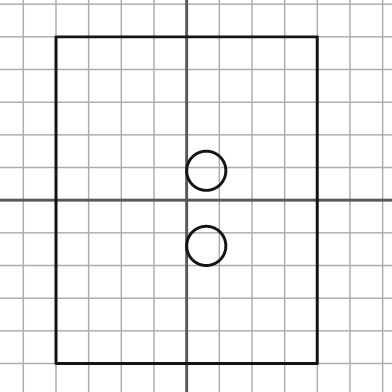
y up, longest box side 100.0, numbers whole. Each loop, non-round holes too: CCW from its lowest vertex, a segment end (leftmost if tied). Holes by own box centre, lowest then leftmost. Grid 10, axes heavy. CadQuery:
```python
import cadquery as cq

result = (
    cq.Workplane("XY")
    .moveTo(-40.0, -50.0)
    .lineTo(40.0, -50.0)
    .lineTo(40.0, 50.0)
    .lineTo(-40.0, 50.0)
    .close()
    .moveTo(6.0, -14.0)
    .circle(6.0)
    .moveTo(6.0, 9.0)
    .circle(6.0)
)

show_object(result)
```